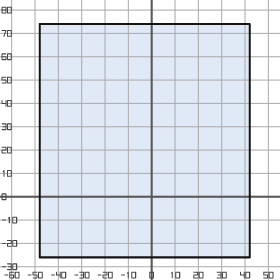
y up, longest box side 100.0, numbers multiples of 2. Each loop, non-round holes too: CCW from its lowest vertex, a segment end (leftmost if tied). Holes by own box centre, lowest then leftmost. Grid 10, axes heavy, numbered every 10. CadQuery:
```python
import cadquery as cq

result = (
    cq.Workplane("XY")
    .moveTo(-48.0, -26.0)
    .lineTo(42.0, -26.0)
    .lineTo(42.0, 74.0)
    .lineTo(-48.0, 74.0)
    .close()
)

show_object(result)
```